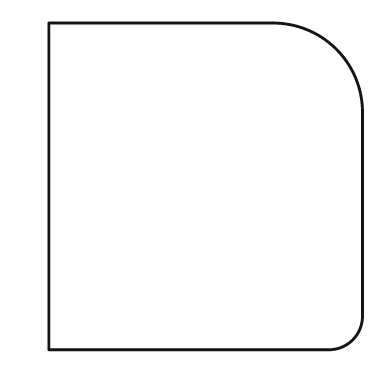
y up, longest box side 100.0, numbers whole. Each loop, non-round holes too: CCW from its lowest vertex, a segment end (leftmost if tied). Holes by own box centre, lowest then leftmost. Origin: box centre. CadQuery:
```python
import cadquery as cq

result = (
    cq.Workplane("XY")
    .moveTo(-48.0, -50.0)
    .lineTo(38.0, -50.0)
    .threePointArc((45.0, -47.0), (48.0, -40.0))
    .lineTo(48.0, 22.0)
    .threePointArc((40.0, 42.0), (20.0, 50.0))
    .lineTo(-48.0, 50.0)
    .close()
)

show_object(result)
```